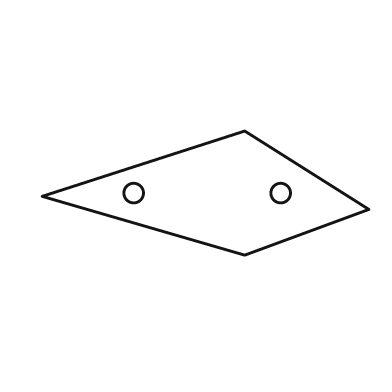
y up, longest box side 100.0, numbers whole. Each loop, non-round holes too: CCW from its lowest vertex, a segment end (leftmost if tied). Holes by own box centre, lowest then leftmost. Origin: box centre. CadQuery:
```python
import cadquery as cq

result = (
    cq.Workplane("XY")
    .moveTo(12.0, -19.0)
    .lineTo(50.0, -5.0)
    .lineTo(12.0, 19.0)
    .lineTo(-50.0, -1.0)
    .close()
    .moveTo(-22.0, 0.0)
    .circle(3.0)
    .moveTo(23.0, 0.0)
    .circle(3.0)
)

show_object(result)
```